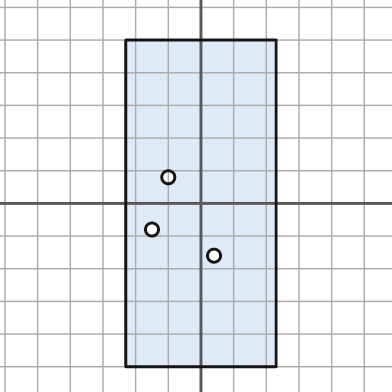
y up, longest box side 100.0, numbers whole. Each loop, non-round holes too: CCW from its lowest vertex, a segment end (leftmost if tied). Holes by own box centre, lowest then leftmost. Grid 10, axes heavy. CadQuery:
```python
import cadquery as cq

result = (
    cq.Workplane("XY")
    .moveTo(-23.0, -50.0)
    .lineTo(23.0, -50.0)
    .lineTo(23.0, 50.0)
    .lineTo(-23.0, 50.0)
    .close()
    .moveTo(4.0, -16.0)
    .circle(2.0)
    .moveTo(-15.0, -8.0)
    .circle(2.0)
    .moveTo(-10.0, 8.0)
    .circle(2.0)
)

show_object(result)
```